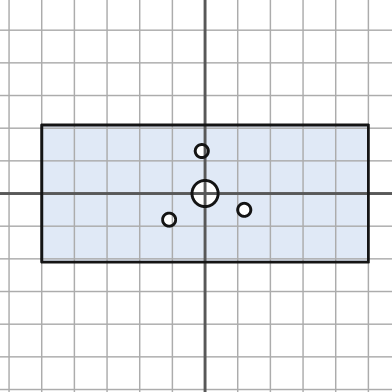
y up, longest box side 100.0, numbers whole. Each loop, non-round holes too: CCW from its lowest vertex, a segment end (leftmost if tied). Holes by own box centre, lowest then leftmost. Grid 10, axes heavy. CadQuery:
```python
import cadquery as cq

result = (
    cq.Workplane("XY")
    .moveTo(-50.0, -21.0)
    .lineTo(50.0, -21.0)
    .lineTo(50.0, 21.0)
    .lineTo(-50.0, 21.0)
    .close()
    .moveTo(-11.0, -8.0)
    .circle(2.0)
    .moveTo(12.0, -5.0)
    .circle(2.0)
    .moveTo(0.0, 0.0)
    .circle(4.0)
    .moveTo(-1.0, 13.0)
    .circle(2.0)
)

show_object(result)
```